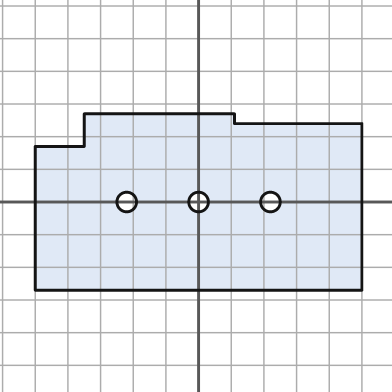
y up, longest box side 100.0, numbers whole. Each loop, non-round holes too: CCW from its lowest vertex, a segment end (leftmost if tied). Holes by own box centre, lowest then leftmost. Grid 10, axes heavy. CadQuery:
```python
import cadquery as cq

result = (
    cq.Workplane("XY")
    .moveTo(-50.0, -27.0)
    .lineTo(50.0, -27.0)
    .lineTo(50.0, 24.0)
    .lineTo(11.0, 24.0)
    .lineTo(11.0, 27.0)
    .lineTo(-35.0, 27.0)
    .lineTo(-35.0, 17.0)
    .lineTo(-50.0, 17.0)
    .close()
    .moveTo(-22.0, 0.0)
    .circle(3.0)
    .moveTo(0.0, 0.0)
    .circle(3.0)
    .moveTo(22.0, 0.0)
    .circle(3.0)
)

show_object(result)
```